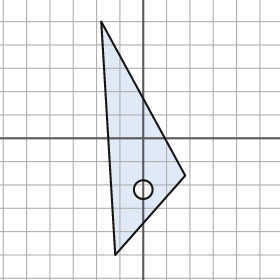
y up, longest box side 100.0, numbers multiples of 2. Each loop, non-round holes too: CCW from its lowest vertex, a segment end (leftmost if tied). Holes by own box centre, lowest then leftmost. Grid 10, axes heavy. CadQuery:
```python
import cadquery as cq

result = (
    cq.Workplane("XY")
    .moveTo(-12.0, -50.0)
    .lineTo(18.0, -16.0)
    .lineTo(-18.0, 50.0)
    .close()
    .moveTo(0.0, -22.0)
    .circle(4.0)
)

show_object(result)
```